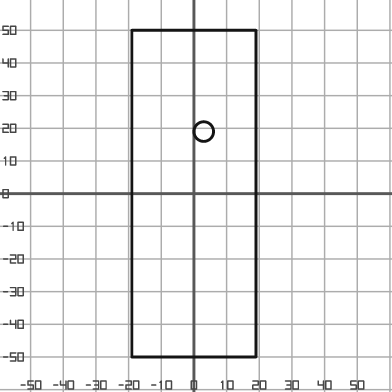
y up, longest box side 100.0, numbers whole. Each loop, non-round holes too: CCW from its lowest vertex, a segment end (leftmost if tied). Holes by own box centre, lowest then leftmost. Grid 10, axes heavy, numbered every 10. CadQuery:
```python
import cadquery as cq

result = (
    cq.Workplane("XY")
    .moveTo(-19.0, -50.0)
    .lineTo(19.0, -50.0)
    .lineTo(19.0, 50.0)
    .lineTo(-19.0, 50.0)
    .close()
    .moveTo(3.0, 19.0)
    .circle(3.0)
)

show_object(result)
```